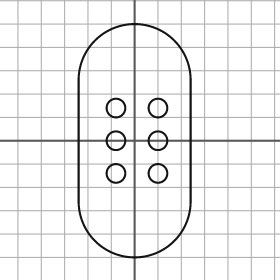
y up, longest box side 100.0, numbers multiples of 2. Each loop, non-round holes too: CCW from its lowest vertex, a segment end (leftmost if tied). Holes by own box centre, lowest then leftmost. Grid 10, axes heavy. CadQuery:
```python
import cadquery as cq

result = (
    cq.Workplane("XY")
    .moveTo(-24.0, -26.0)
    .threePointArc((0.0, -50.0), (24.0, -26.0))
    .lineTo(24.0, 26.0)
    .threePointArc((0.0, 50.0), (-24.0, 26.0))
    .close()
    .moveTo(-8.0, -14.0)
    .circle(4.0)
    .moveTo(10.0, -14.0)
    .circle(4.0)
    .moveTo(-8.0, 0.0)
    .circle(4.0)
    .moveTo(10.0, 0.0)
    .circle(4.0)
    .moveTo(-8.0, 14.0)
    .circle(4.0)
    .moveTo(10.0, 14.0)
    .circle(4.0)
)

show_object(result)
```